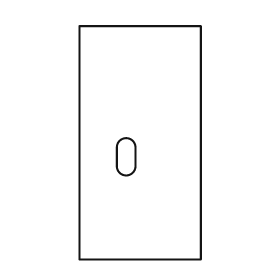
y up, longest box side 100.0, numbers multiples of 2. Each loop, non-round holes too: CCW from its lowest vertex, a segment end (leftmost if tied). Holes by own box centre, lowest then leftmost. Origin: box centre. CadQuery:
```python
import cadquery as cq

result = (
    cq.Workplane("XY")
    .moveTo(-26.0, -50.0)
    .lineTo(26.0, -50.0)
    .lineTo(26.0, 50.0)
    .lineTo(-26.0, 50.0)
    .close()
    .moveTo(-10.0, -10.0)
    .threePointArc((-6.0, -14.0), (-2.0, -10.0))
    .lineTo(-2.0, -2.0)
    .threePointArc((-6.0, 2.0), (-10.0, -2.0))
    .close()
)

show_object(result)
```